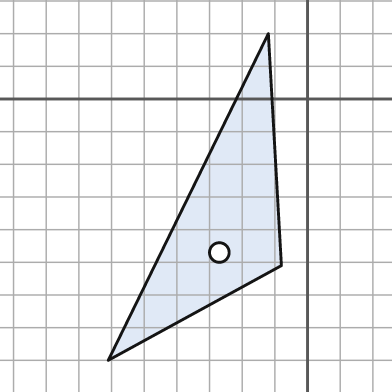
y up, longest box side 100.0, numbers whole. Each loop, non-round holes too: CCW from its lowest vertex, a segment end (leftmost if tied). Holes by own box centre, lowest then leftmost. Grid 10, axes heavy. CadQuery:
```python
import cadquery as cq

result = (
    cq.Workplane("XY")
    .moveTo(-61.0, -80.0)
    .lineTo(-8.0, -51.0)
    .lineTo(-12.0, 20.0)
    .close()
    .moveTo(-27.0, -47.0)
    .circle(3.0)
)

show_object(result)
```